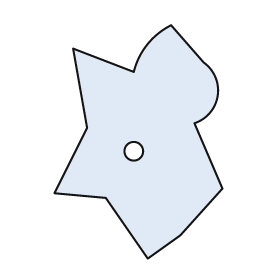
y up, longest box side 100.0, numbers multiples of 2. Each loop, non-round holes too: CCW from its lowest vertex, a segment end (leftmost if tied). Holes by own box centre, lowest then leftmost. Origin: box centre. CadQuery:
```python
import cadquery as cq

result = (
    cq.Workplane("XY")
    .moveTo(4.0, -50.0)
    .lineTo(18.0, -40.0)
    .lineTo(36.0, -20.0)
    .lineTo(24.0, 8.0)
    .threePointArc((34.0, 20.0), (28.0, 34.0))
    .lineTo(14.0, 50.0)
    .threePointArc((4.0, 42.0), (-2.0, 30.0))
    .lineTo(-28.0, 40.0)
    .lineTo(-22.0, 6.0)
    .lineTo(-36.0, -22.0)
    .lineTo(-14.0, -24.0)
    .close()
    .moveTo(-2.0, -4.0)
    .circle(4.0)
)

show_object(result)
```